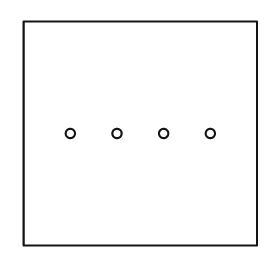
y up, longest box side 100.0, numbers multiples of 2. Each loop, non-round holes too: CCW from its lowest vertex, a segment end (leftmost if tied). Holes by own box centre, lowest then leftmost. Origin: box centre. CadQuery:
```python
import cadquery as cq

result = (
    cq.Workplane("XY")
    .moveTo(-50.0, -48.0)
    .lineTo(50.0, -48.0)
    .lineTo(50.0, 48.0)
    .lineTo(-50.0, 48.0)
    .close()
    .moveTo(-30.0, 0.0)
    .circle(2.0)
    .moveTo(-10.0, 0.0)
    .circle(2.0)
    .moveTo(10.0, 0.0)
    .circle(2.0)
    .moveTo(30.0, 0.0)
    .circle(2.0)
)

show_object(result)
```